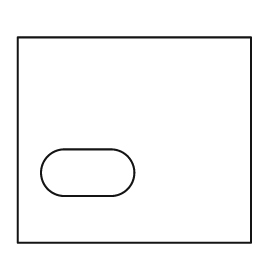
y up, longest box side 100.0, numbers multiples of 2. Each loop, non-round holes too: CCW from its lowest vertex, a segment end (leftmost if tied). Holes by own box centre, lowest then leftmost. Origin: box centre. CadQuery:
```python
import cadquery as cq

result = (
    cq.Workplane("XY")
    .moveTo(-50.0, -44.0)
    .lineTo(50.0, -44.0)
    .lineTo(50.0, 44.0)
    .lineTo(-50.0, 44.0)
    .close()
    .moveTo(-30.0, -24.0)
    .lineTo(-10.0, -24.0)
    .threePointArc((0.0, -14.0), (-10.0, -4.0))
    .lineTo(-30.0, -4.0)
    .threePointArc((-40.0, -14.0), (-30.0, -24.0))
    .close()
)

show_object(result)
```